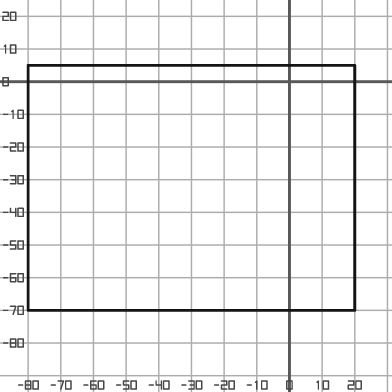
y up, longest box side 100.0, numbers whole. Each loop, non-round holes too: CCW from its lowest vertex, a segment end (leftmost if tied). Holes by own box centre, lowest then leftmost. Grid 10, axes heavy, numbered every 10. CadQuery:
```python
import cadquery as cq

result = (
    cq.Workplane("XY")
    .moveTo(-80.0, -70.0)
    .lineTo(20.0, -70.0)
    .lineTo(20.0, 5.0)
    .lineTo(-80.0, 5.0)
    .close()
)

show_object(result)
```